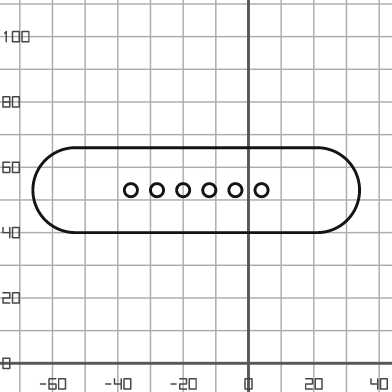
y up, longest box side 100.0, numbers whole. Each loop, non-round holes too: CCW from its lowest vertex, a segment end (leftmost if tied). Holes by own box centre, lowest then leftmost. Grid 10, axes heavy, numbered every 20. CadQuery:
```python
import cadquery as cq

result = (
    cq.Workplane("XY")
    .moveTo(-53.0, 40.0)
    .lineTo(21.0, 40.0)
    .threePointArc((34.0, 53.0), (21.0, 66.0))
    .lineTo(-53.0, 66.0)
    .threePointArc((-66.0, 53.0), (-53.0, 40.0))
    .close()
    .moveTo(-36.0, 53.0)
    .circle(2.0)
    .moveTo(-28.0, 53.0)
    .circle(2.0)
    .moveTo(-20.0, 53.0)
    .circle(2.0)
    .moveTo(-12.0, 53.0)
    .circle(2.0)
    .moveTo(-4.0, 53.0)
    .circle(2.0)
    .moveTo(4.0, 53.0)
    .circle(2.0)
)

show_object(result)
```